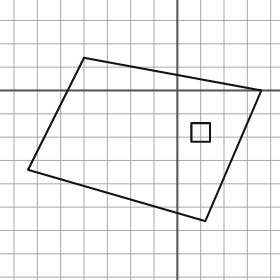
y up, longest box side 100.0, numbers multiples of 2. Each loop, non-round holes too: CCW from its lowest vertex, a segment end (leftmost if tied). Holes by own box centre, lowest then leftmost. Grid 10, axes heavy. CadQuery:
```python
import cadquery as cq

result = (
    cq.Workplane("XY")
    .moveTo(12.0, -56.0)
    .lineTo(36.0, 0.0)
    .lineTo(-40.0, 14.0)
    .lineTo(-64.0, -34.0)
    .close()
    .moveTo(6.0, -22.0)
    .lineTo(14.0, -22.0)
    .lineTo(14.0, -14.0)
    .lineTo(6.0, -14.0)
    .close()
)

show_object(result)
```